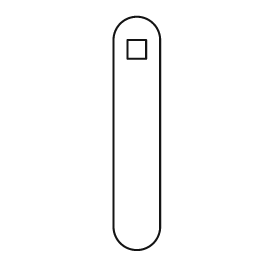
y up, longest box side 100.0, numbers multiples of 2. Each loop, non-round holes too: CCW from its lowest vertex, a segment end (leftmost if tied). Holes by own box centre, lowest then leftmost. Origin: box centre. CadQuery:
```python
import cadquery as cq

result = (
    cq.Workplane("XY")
    .moveTo(-10.0, -40.0)
    .threePointArc((0.0, -50.0), (10.0, -40.0))
    .lineTo(10.0, 40.0)
    .threePointArc((0.0, 50.0), (-10.0, 40.0))
    .close()
    .moveTo(-4.0, 32.0)
    .lineTo(4.0, 32.0)
    .lineTo(4.0, 40.0)
    .lineTo(-4.0, 40.0)
    .close()
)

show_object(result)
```